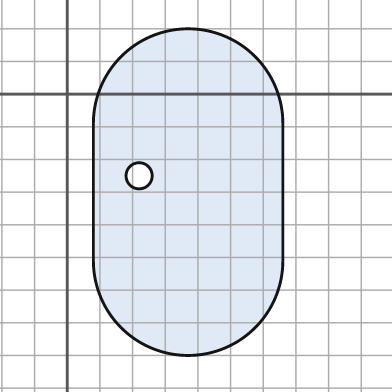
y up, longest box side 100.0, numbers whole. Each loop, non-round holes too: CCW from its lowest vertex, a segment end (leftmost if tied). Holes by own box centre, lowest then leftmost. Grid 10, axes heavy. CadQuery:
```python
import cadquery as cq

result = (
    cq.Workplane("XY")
    .moveTo(8.0, -51.0)
    .threePointArc((37.0, -80.0), (66.0, -51.0))
    .lineTo(66.0, -9.0)
    .threePointArc((37.0, 20.0), (8.0, -9.0))
    .close()
    .moveTo(22.0, -25.0)
    .circle(4.0)
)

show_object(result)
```